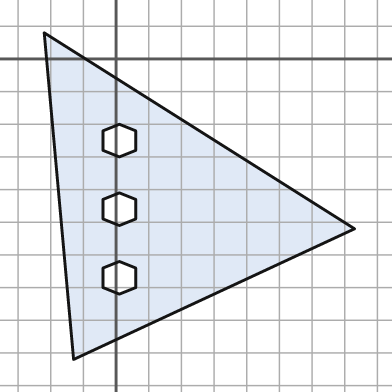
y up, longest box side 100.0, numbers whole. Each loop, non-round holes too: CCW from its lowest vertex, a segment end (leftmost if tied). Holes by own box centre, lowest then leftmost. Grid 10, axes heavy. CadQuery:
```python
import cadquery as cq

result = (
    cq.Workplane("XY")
    .moveTo(-13.0, -92.0)
    .lineTo(73.0, -52.0)
    .lineTo(-22.0, 8.0)
    .close()
    .moveTo(1.0, -72.0)
    .lineTo(6.0, -70.0)
    .lineTo(6.0, -64.0)
    .lineTo(1.0, -62.0)
    .lineTo(-4.0, -64.0)
    .lineTo(-4.0, -70.0)
    .close()
    .moveTo(1.0, -51.0)
    .lineTo(6.0, -49.0)
    .lineTo(6.0, -43.0)
    .lineTo(1.0, -41.0)
    .lineTo(-4.0, -43.0)
    .lineTo(-4.0, -49.0)
    .close()
    .moveTo(1.0, -30.0)
    .lineTo(6.0, -28.0)
    .lineTo(6.0, -22.0)
    .lineTo(1.0, -20.0)
    .lineTo(-4.0, -22.0)
    .lineTo(-4.0, -28.0)
    .close()
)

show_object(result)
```